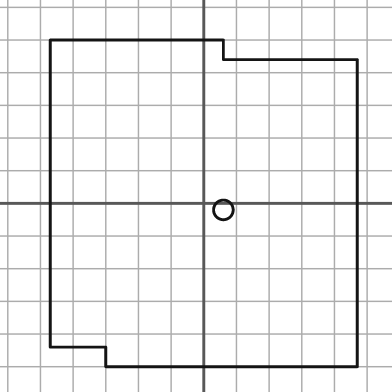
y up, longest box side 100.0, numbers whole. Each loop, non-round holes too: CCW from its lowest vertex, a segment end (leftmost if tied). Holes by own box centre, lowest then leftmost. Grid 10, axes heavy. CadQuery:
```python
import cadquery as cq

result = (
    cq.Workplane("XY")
    .moveTo(-30.0, -50.0)
    .lineTo(47.0, -50.0)
    .lineTo(47.0, 44.0)
    .lineTo(6.0, 44.0)
    .lineTo(6.0, 50.0)
    .lineTo(-47.0, 50.0)
    .lineTo(-47.0, -44.0)
    .lineTo(-30.0, -44.0)
    .close()
    .moveTo(6.0, -2.0)
    .circle(3.0)
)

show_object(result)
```